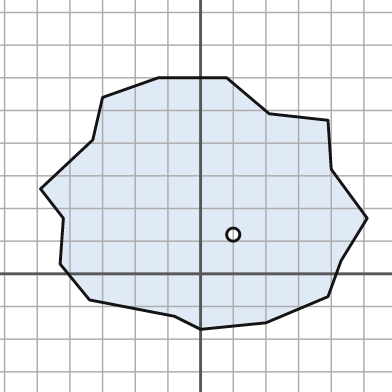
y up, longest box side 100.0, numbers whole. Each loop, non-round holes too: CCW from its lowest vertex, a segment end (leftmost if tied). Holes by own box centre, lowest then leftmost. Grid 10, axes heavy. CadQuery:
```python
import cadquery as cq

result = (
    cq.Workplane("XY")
    .moveTo(0.0, -17.0)
    .lineTo(20.0, -15.0)
    .lineTo(39.0, -7.0)
    .lineTo(43.0, 4.0)
    .lineTo(51.0, 17.0)
    .lineTo(40.0, 32.0)
    .lineTo(39.0, 47.0)
    .lineTo(21.0, 49.0)
    .lineTo(8.0, 60.0)
    .lineTo(-13.0, 60.0)
    .lineTo(-30.0, 54.0)
    .lineTo(-33.0, 41.0)
    .lineTo(-49.0, 26.0)
    .lineTo(-42.0, 17.0)
    .lineTo(-43.0, 3.0)
    .lineTo(-34.0, -8.0)
    .lineTo(-8.0, -13.0)
    .close()
    .moveTo(10.0, 12.0)
    .circle(2.0)
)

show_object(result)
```